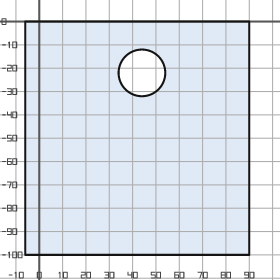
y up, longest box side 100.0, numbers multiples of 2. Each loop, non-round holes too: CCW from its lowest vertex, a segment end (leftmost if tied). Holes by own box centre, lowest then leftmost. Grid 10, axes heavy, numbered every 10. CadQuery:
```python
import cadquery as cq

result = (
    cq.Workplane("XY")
    .moveTo(-6.0, -100.0)
    .lineTo(90.0, -100.0)
    .lineTo(90.0, 0.0)
    .lineTo(-6.0, 0.0)
    .close()
    .moveTo(44.0, -22.0)
    .circle(10.0)
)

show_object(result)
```